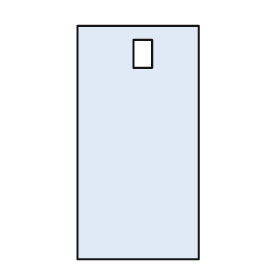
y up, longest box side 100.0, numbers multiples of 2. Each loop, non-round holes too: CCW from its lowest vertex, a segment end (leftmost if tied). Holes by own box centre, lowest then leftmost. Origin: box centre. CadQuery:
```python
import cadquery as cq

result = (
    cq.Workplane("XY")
    .moveTo(-26.0, -50.0)
    .lineTo(26.0, -50.0)
    .lineTo(26.0, 50.0)
    .lineTo(-26.0, 50.0)
    .close()
    .moveTo(-2.0, 32.0)
    .lineTo(6.0, 32.0)
    .lineTo(6.0, 44.0)
    .lineTo(-2.0, 44.0)
    .close()
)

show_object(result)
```